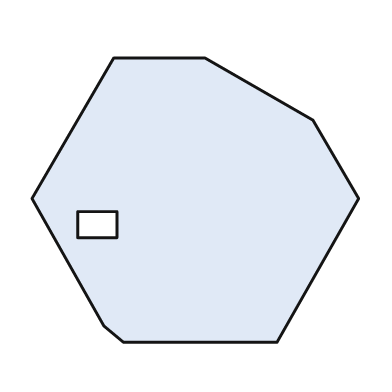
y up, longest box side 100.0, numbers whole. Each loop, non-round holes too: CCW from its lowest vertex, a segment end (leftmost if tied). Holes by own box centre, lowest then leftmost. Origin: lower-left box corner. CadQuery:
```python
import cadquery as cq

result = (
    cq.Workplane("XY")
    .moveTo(28.0, 0.0)
    .lineTo(75.0, 0.0)
    .lineTo(100.0, 44.0)
    .lineTo(86.0, 68.0)
    .lineTo(53.0, 87.0)
    .lineTo(25.0, 87.0)
    .lineTo(0.0, 44.0)
    .lineTo(22.0, 5.0)
    .close()
    .moveTo(14.0, 32.0)
    .lineTo(26.0, 32.0)
    .lineTo(26.0, 40.0)
    .lineTo(14.0, 40.0)
    .close()
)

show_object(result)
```